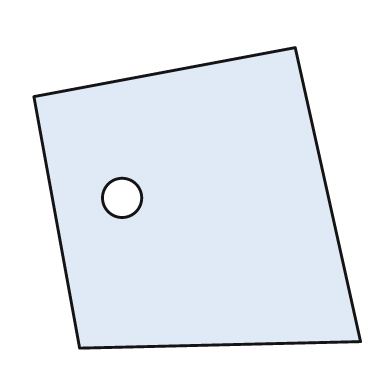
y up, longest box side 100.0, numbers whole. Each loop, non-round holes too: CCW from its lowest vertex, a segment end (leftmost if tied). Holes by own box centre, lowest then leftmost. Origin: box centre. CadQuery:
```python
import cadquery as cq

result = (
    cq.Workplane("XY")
    .moveTo(-36.0, -46.0)
    .lineTo(50.0, -44.0)
    .lineTo(30.0, 46.0)
    .lineTo(-50.0, 31.0)
    .close()
    .moveTo(-23.0, 0.0)
    .circle(6.0)
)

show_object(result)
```